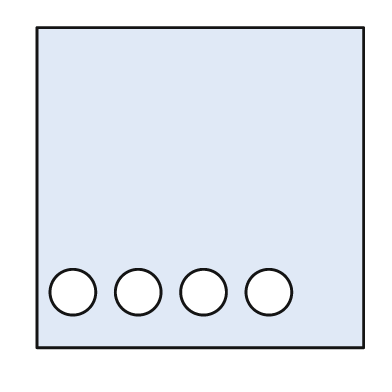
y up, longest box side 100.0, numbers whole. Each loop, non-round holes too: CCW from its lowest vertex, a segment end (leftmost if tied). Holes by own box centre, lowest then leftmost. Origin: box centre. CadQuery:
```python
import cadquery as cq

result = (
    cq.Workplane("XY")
    .moveTo(-50.0, -49.0)
    .lineTo(50.0, -49.0)
    .lineTo(50.0, 49.0)
    .lineTo(-50.0, 49.0)
    .close()
    .moveTo(-39.0, -32.0)
    .circle(7.0)
    .moveTo(-19.0, -32.0)
    .circle(7.0)
    .moveTo(1.0, -32.0)
    .circle(7.0)
    .moveTo(21.0, -32.0)
    .circle(7.0)
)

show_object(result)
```